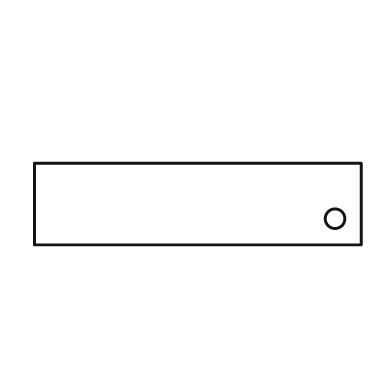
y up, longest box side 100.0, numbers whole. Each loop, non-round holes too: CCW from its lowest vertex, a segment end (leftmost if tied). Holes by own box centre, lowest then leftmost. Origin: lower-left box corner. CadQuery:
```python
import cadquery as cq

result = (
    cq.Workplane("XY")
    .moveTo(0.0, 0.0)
    .lineTo(100.0, 0.0)
    .lineTo(100.0, 25.0)
    .lineTo(0.0, 25.0)
    .close()
    .moveTo(92.0, 8.0)
    .circle(3.0)
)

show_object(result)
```